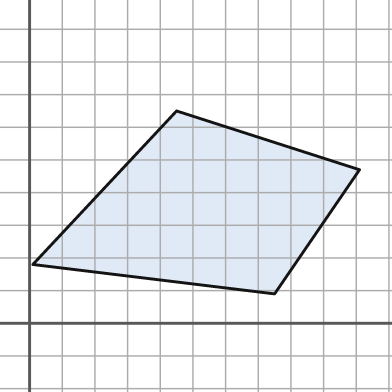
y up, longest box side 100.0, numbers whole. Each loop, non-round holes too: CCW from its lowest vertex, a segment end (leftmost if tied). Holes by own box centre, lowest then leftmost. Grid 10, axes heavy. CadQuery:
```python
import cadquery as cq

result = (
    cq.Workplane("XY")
    .moveTo(75.0, 9.0)
    .lineTo(101.0, 47.0)
    .lineTo(45.0, 65.0)
    .lineTo(1.0, 18.0)
    .close()
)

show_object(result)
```